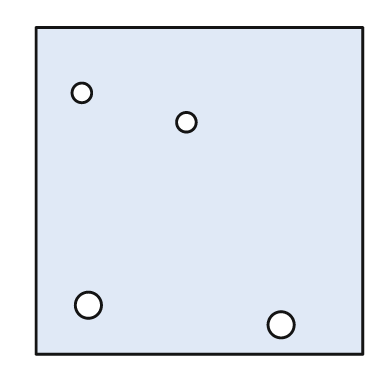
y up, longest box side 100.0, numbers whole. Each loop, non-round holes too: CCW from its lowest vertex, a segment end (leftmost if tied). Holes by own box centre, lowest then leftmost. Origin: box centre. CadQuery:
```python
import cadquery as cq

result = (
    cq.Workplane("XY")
    .moveTo(-50.0, -50.0)
    .lineTo(50.0, -50.0)
    .lineTo(50.0, 50.0)
    .lineTo(-50.0, 50.0)
    .close()
    .moveTo(25.0, -41.0)
    .circle(4.0)
    .moveTo(-34.0, -35.0)
    .circle(4.0)
    .moveTo(-4.0, 21.0)
    .circle(3.0)
    .moveTo(-36.0, 30.0)
    .circle(3.0)
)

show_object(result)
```